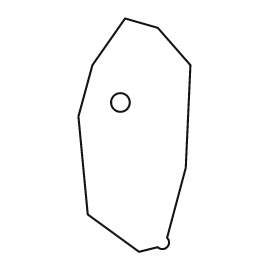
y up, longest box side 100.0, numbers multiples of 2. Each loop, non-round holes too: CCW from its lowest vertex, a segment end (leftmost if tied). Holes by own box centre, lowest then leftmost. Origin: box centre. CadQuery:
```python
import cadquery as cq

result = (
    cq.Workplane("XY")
    .moveTo(2.0, -50.0)
    .lineTo(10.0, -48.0)
    .threePointArc((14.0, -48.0), (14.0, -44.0))
    .lineTo(22.0, -14.0)
    .lineTo(24.0, 30.0)
    .lineTo(10.0, 46.0)
    .lineTo(-4.0, 50.0)
    .lineTo(-18.0, 30.0)
    .lineTo(-24.0, 8.0)
    .lineTo(-20.0, -34.0)
    .close()
    .moveTo(-6.0, 14.0)
    .circle(4.0)
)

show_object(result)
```